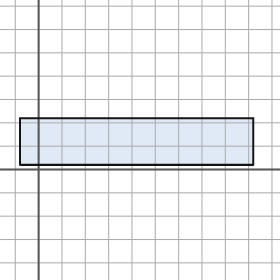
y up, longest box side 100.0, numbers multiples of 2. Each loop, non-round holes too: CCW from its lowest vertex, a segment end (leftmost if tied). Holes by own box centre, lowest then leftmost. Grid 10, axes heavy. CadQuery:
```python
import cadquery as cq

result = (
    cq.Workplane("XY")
    .moveTo(-8.0, 2.0)
    .lineTo(92.0, 2.0)
    .lineTo(92.0, 22.0)
    .lineTo(-8.0, 22.0)
    .close()
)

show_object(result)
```